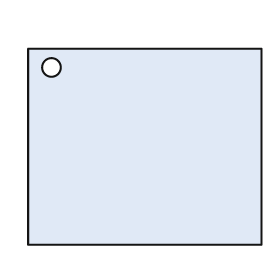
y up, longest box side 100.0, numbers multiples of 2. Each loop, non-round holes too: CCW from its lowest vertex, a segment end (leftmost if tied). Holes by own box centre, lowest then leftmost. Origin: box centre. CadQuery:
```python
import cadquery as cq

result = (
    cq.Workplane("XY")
    .moveTo(-50.0, -42.0)
    .lineTo(50.0, -42.0)
    .lineTo(50.0, 42.0)
    .lineTo(-50.0, 42.0)
    .close()
    .moveTo(-40.0, 34.0)
    .circle(4.0)
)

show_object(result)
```